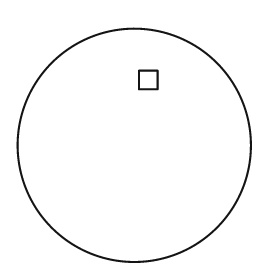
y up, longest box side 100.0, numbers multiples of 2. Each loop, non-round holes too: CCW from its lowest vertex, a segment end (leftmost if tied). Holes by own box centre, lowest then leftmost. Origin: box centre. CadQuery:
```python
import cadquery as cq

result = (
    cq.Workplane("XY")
    .moveTo(0.0, 0.0)
    .circle(50.0)
    .moveTo(2.0, 24.0)
    .lineTo(10.0, 24.0)
    .lineTo(10.0, 32.0)
    .lineTo(2.0, 32.0)
    .close()
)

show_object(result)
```